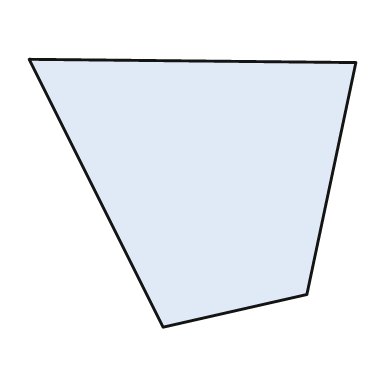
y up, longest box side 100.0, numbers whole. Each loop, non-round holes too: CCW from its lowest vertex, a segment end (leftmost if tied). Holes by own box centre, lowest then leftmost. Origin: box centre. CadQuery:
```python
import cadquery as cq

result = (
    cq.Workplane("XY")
    .moveTo(-9.0, -41.0)
    .lineTo(35.0, -31.0)
    .lineTo(50.0, 40.0)
    .lineTo(-50.0, 41.0)
    .close()
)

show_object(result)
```